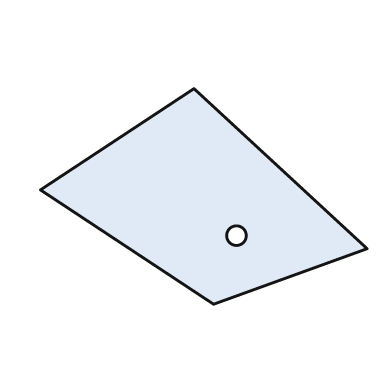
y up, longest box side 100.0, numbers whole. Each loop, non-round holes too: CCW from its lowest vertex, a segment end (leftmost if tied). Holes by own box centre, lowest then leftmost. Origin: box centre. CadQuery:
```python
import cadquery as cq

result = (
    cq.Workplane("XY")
    .moveTo(3.0, -33.0)
    .lineTo(50.0, -16.0)
    .lineTo(-3.0, 33.0)
    .lineTo(-50.0, 2.0)
    .close()
    .moveTo(10.0, -12.0)
    .circle(3.0)
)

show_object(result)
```